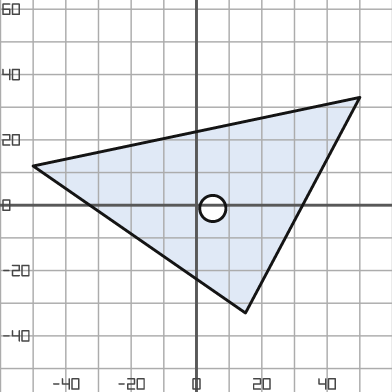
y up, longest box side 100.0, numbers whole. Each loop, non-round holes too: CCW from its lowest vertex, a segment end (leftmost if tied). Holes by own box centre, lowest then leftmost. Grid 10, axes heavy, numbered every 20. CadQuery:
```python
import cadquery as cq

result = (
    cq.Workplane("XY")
    .moveTo(15.0, -33.0)
    .lineTo(50.0, 33.0)
    .lineTo(-50.0, 12.0)
    .close()
    .moveTo(5.0, -1.0)
    .circle(4.0)
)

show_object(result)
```